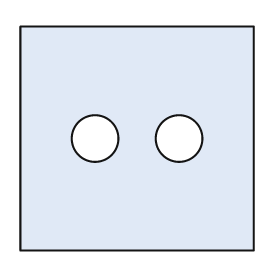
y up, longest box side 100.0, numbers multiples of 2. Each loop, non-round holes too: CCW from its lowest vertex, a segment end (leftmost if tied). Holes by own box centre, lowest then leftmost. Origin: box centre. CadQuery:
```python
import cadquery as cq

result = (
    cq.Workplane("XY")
    .moveTo(-50.0, -48.0)
    .lineTo(50.0, -48.0)
    .lineTo(50.0, 48.0)
    .lineTo(-50.0, 48.0)
    .close()
    .moveTo(-18.0, 0.0)
    .circle(10.0)
    .moveTo(18.0, 0.0)
    .circle(10.0)
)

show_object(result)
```